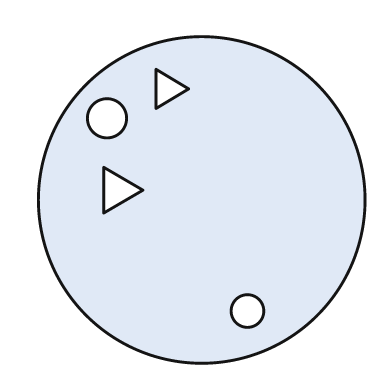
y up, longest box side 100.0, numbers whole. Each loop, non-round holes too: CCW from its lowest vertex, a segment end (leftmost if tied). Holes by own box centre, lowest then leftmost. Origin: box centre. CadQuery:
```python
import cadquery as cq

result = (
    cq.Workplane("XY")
    .moveTo(0.0, 0.0)
    .circle(50.0)
    .moveTo(14.0, -34.0)
    .circle(5.0)
    .moveTo(-30.0, -4.0)
    .lineTo(-18.0, 3.0)
    .lineTo(-30.0, 10.0)
    .close()
    .moveTo(-29.0, 25.0)
    .circle(6.0)
    .moveTo(-14.0, 28.0)
    .lineTo(-4.0, 34.0)
    .lineTo(-14.0, 40.0)
    .close()
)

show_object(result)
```